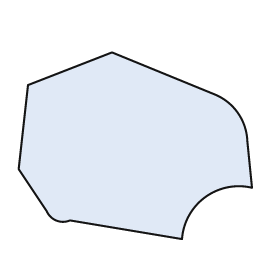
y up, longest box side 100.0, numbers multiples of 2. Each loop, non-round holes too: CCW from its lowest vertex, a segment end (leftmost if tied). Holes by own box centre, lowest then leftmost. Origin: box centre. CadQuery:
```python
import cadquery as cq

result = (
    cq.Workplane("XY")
    .moveTo(20.0, -40.0)
    .threePointArc((30.0, -22.0), (50.0, -18.0))
    .lineTo(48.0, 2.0)
    .threePointArc((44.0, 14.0), (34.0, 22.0))
    .lineTo(-10.0, 40.0)
    .lineTo(-46.0, 26.0)
    .lineTo(-50.0, -10.0)
    .lineTo(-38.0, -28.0)
    .threePointArc((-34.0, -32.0), (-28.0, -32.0))
    .close()
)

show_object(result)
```